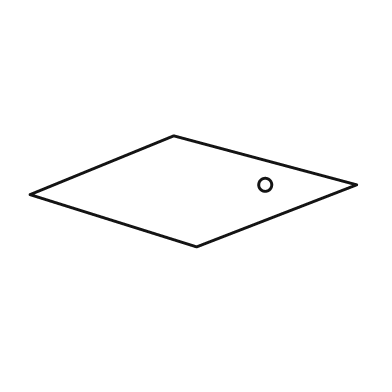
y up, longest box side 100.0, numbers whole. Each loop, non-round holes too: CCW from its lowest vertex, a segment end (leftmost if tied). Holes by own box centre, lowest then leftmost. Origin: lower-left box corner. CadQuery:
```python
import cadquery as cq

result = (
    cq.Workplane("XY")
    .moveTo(51.0, 0.0)
    .lineTo(100.0, 19.0)
    .lineTo(44.0, 34.0)
    .lineTo(0.0, 16.0)
    .close()
    .moveTo(72.0, 19.0)
    .circle(2.0)
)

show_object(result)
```